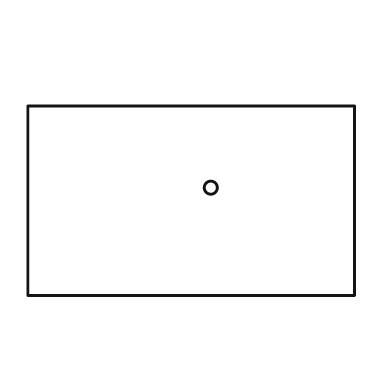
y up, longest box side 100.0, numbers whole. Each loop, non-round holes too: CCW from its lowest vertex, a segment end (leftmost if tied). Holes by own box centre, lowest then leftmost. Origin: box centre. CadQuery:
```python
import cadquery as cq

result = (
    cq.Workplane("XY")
    .moveTo(-50.0, -29.0)
    .lineTo(50.0, -29.0)
    .lineTo(50.0, 29.0)
    .lineTo(-50.0, 29.0)
    .close()
    .moveTo(6.0, 4.0)
    .circle(2.0)
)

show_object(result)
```